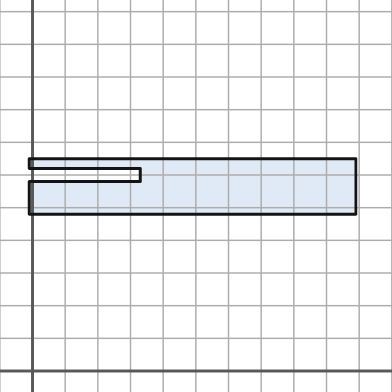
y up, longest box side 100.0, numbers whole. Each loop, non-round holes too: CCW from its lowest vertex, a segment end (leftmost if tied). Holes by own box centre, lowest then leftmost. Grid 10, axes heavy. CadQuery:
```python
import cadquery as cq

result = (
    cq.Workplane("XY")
    .moveTo(-1.0, 48.0)
    .lineTo(99.0, 48.0)
    .lineTo(99.0, 65.0)
    .lineTo(-1.0, 65.0)
    .lineTo(-1.0, 62.0)
    .lineTo(33.0, 62.0)
    .lineTo(33.0, 58.0)
    .lineTo(-1.0, 58.0)
    .close()
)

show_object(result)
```